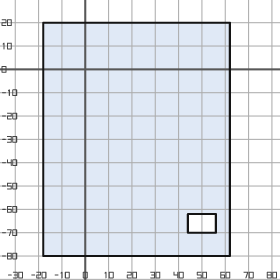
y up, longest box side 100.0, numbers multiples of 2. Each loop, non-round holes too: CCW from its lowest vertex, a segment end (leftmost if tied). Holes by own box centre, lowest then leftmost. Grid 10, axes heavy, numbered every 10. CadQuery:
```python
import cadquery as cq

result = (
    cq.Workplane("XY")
    .moveTo(-18.0, -80.0)
    .lineTo(62.0, -80.0)
    .lineTo(62.0, 20.0)
    .lineTo(-18.0, 20.0)
    .close()
    .moveTo(44.0, -70.0)
    .lineTo(56.0, -70.0)
    .lineTo(56.0, -62.0)
    .lineTo(44.0, -62.0)
    .close()
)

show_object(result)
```